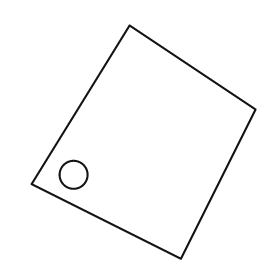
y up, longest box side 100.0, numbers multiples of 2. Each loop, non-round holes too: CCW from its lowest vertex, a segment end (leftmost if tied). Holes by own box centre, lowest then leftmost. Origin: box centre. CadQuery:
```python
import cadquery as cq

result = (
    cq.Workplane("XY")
    .moveTo(16.0, -50.0)
    .lineTo(48.0, 14.0)
    .lineTo(-6.0, 50.0)
    .lineTo(-48.0, -18.0)
    .close()
    .moveTo(-30.0, -14.0)
    .circle(6.0)
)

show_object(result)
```